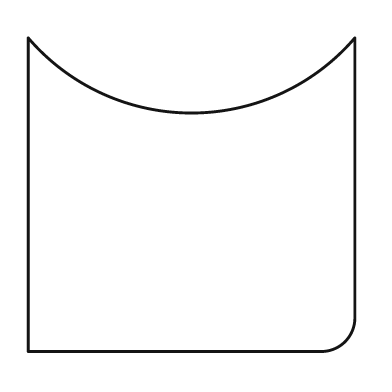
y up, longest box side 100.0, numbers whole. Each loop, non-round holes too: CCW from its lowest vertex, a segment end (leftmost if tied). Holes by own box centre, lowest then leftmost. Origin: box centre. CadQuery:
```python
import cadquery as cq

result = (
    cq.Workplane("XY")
    .moveTo(-50.0, -48.0)
    .lineTo(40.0, -48.0)
    .threePointArc((47.0, -45.0), (50.0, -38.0))
    .lineTo(50.0, 48.0)
    .threePointArc((0.0, 25.0), (-50.0, 48.0))
    .close()
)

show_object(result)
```